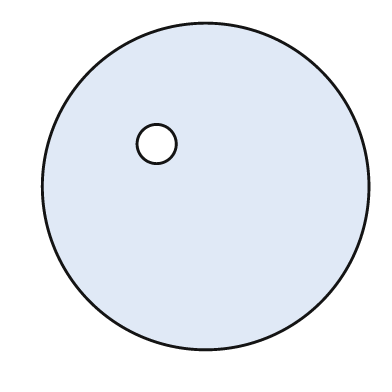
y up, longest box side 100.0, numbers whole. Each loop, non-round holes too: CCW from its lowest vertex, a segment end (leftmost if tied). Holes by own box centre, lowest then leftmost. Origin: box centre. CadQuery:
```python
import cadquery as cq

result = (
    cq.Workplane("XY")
    .moveTo(0.0, 0.0)
    .circle(50.0)
    .moveTo(-15.0, 13.0)
    .circle(6.0)
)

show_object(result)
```